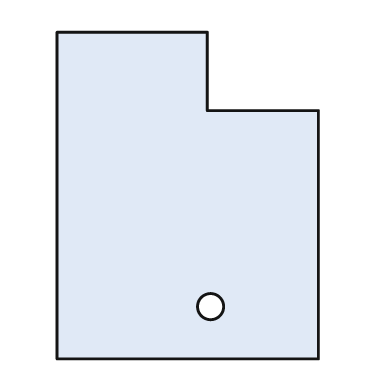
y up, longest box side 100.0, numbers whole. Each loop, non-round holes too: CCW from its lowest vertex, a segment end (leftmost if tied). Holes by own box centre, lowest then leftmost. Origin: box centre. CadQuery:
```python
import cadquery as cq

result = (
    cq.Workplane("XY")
    .moveTo(-40.0, -50.0)
    .lineTo(40.0, -50.0)
    .lineTo(40.0, 26.0)
    .lineTo(6.0, 26.0)
    .lineTo(6.0, 50.0)
    .lineTo(-40.0, 50.0)
    .close()
    .moveTo(7.0, -34.0)
    .circle(4.0)
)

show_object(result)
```